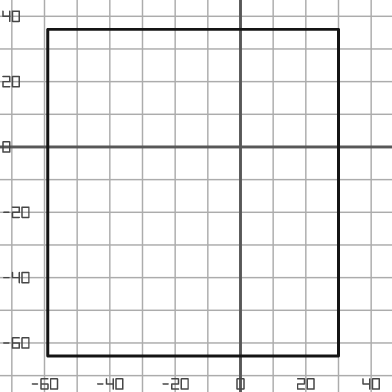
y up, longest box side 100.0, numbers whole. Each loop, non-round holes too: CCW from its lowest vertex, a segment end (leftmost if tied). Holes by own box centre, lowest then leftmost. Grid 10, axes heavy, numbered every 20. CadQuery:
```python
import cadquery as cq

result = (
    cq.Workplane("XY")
    .moveTo(-59.0, -64.0)
    .lineTo(30.0, -64.0)
    .lineTo(30.0, 36.0)
    .lineTo(-59.0, 36.0)
    .close()
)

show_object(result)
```